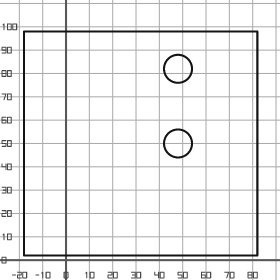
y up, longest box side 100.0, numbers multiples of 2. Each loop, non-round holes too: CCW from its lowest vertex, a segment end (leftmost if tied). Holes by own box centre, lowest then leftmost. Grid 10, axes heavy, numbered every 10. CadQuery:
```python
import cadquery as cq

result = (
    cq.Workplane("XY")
    .moveTo(-18.0, 2.0)
    .lineTo(82.0, 2.0)
    .lineTo(82.0, 98.0)
    .lineTo(-18.0, 98.0)
    .close()
    .moveTo(48.0, 50.0)
    .circle(6.0)
    .moveTo(48.0, 82.0)
    .circle(6.0)
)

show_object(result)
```